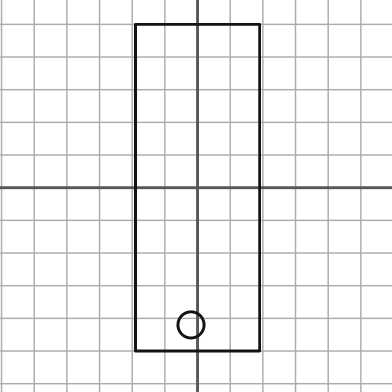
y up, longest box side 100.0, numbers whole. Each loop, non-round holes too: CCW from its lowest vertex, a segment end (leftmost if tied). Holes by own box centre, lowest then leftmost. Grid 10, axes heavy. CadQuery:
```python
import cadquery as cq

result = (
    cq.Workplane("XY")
    .moveTo(-19.0, -50.0)
    .lineTo(19.0, -50.0)
    .lineTo(19.0, 50.0)
    .lineTo(-19.0, 50.0)
    .close()
    .moveTo(-2.0, -42.0)
    .circle(4.0)
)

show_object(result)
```